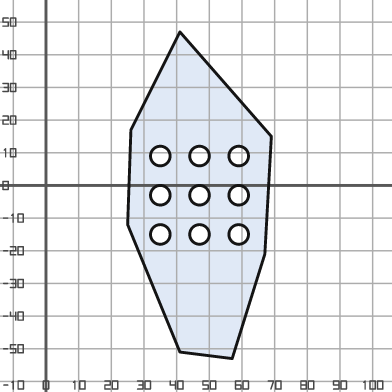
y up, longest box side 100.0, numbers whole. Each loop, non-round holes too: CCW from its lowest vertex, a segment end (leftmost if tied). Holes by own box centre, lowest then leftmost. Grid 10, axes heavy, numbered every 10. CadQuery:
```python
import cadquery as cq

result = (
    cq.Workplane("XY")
    .moveTo(57.0, -53.0)
    .lineTo(67.0, -21.0)
    .lineTo(69.0, 15.0)
    .lineTo(41.0, 47.0)
    .lineTo(26.0, 17.0)
    .lineTo(25.0, -12.0)
    .lineTo(41.0, -51.0)
    .close()
    .moveTo(35.0, -15.0)
    .circle(3.0)
    .moveTo(47.0, -15.0)
    .circle(3.0)
    .moveTo(59.0, -15.0)
    .circle(3.0)
    .moveTo(35.0, -3.0)
    .circle(3.0)
    .moveTo(47.0, -3.0)
    .circle(3.0)
    .moveTo(59.0, -3.0)
    .circle(3.0)
    .moveTo(35.0, 9.0)
    .circle(3.0)
    .moveTo(47.0, 9.0)
    .circle(3.0)
    .moveTo(59.0, 9.0)
    .circle(3.0)
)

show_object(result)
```